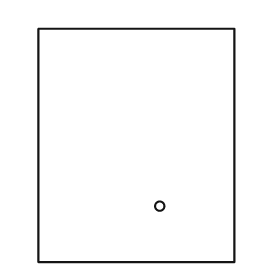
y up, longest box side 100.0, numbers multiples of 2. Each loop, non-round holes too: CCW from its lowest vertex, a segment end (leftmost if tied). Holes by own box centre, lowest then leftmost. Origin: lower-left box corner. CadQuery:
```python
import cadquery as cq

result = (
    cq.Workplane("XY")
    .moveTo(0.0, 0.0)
    .lineTo(84.0, 0.0)
    .lineTo(84.0, 100.0)
    .lineTo(0.0, 100.0)
    .close()
    .moveTo(52.0, 24.0)
    .circle(2.0)
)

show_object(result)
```